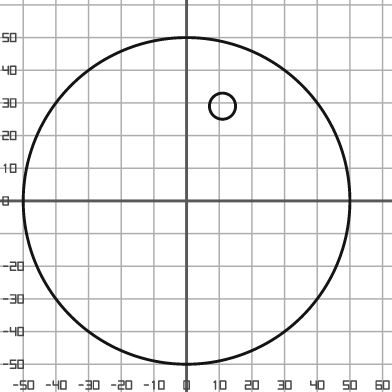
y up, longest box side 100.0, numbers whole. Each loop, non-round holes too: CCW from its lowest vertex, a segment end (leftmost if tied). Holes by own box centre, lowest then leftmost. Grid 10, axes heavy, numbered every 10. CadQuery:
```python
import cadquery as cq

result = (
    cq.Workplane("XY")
    .moveTo(0.0, 0.0)
    .circle(50.0)
    .moveTo(11.0, 29.0)
    .circle(4.0)
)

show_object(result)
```